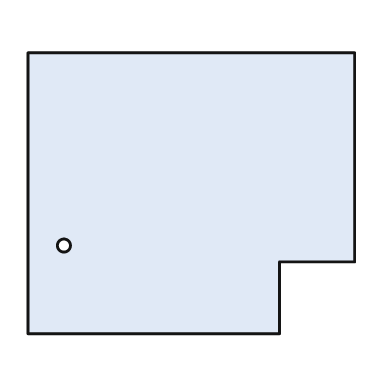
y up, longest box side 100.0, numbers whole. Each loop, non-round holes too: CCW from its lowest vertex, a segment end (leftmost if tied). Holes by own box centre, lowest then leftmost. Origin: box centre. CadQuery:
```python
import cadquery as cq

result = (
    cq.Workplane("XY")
    .moveTo(-50.0, -43.0)
    .lineTo(27.0, -43.0)
    .lineTo(27.0, -21.0)
    .lineTo(50.0, -21.0)
    .lineTo(50.0, 43.0)
    .lineTo(-50.0, 43.0)
    .close()
    .moveTo(-39.0, -16.0)
    .circle(2.0)
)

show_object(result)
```